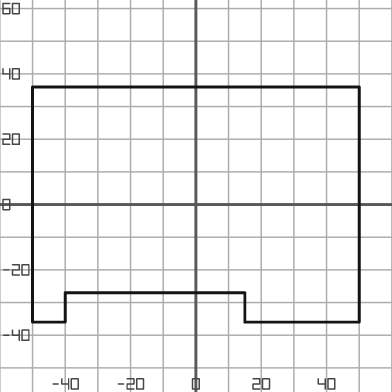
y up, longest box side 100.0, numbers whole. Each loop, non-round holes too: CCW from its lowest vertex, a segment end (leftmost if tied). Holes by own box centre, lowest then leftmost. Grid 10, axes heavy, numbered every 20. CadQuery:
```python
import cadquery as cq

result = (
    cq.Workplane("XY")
    .moveTo(-50.0, -36.0)
    .lineTo(-40.0, -36.0)
    .lineTo(-40.0, -27.0)
    .lineTo(15.0, -27.0)
    .lineTo(15.0, -36.0)
    .lineTo(50.0, -36.0)
    .lineTo(50.0, 36.0)
    .lineTo(-50.0, 36.0)
    .close()
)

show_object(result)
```